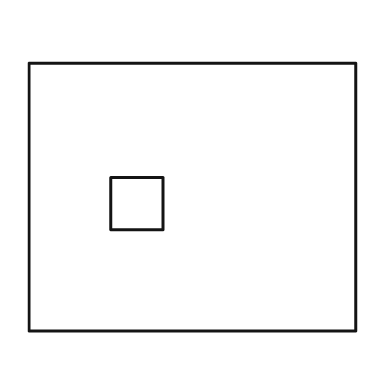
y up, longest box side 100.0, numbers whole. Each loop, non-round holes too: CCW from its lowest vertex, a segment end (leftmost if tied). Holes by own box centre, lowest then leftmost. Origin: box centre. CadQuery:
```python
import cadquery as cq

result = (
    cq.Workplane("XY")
    .moveTo(-50.0, -41.0)
    .lineTo(50.0, -41.0)
    .lineTo(50.0, 41.0)
    .lineTo(-50.0, 41.0)
    .close()
    .moveTo(-25.0, -10.0)
    .lineTo(-9.0, -10.0)
    .lineTo(-9.0, 6.0)
    .lineTo(-25.0, 6.0)
    .close()
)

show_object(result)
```